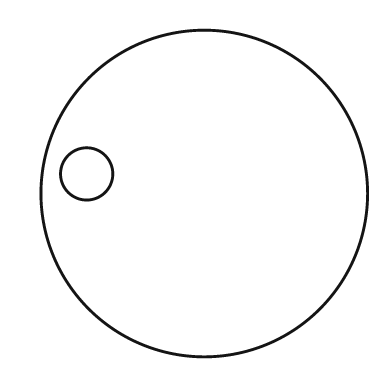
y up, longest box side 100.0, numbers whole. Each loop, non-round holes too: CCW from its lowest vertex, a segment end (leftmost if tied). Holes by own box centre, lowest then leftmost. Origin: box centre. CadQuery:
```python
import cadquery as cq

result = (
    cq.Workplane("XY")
    .moveTo(0.0, 0.0)
    .circle(50.0)
    .moveTo(-36.0, 6.0)
    .circle(8.0)
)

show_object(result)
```